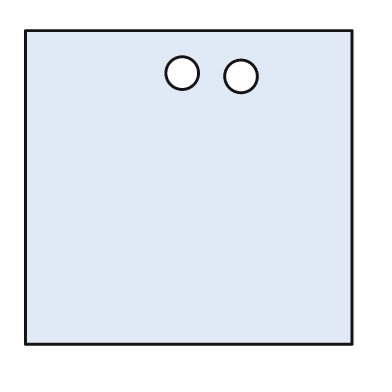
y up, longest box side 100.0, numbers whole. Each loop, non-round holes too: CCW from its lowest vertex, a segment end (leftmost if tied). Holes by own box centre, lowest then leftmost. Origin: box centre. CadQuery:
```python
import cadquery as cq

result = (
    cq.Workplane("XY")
    .moveTo(-50.0, -48.0)
    .lineTo(50.0, -48.0)
    .lineTo(50.0, 48.0)
    .lineTo(-50.0, 48.0)
    .close()
    .moveTo(16.0, 34.0)
    .circle(5.0)
    .moveTo(-2.0, 35.0)
    .circle(5.0)
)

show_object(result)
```